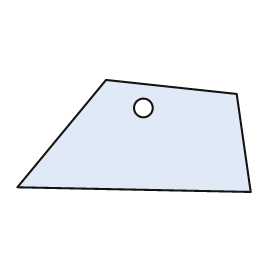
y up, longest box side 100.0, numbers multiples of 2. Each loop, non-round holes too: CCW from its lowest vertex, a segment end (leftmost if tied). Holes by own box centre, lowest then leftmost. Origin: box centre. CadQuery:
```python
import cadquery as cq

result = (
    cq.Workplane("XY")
    .moveTo(50.0, -24.0)
    .lineTo(44.0, 18.0)
    .lineTo(-12.0, 24.0)
    .lineTo(-50.0, -22.0)
    .close()
    .moveTo(4.0, 12.0)
    .circle(4.0)
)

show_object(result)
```